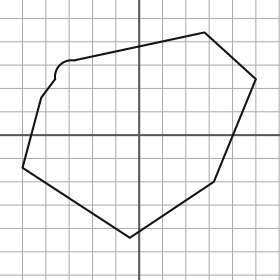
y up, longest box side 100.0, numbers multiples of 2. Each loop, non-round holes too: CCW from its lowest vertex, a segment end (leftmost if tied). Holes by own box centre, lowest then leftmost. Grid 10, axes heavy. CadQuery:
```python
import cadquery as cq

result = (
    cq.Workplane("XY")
    .moveTo(-4.0, -44.0)
    .lineTo(32.0, -20.0)
    .lineTo(50.0, 24.0)
    .lineTo(28.0, 44.0)
    .lineTo(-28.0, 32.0)
    .threePointArc((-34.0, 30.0), (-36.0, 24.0))
    .lineTo(-42.0, 16.0)
    .lineTo(-50.0, -14.0)
    .close()
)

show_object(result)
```